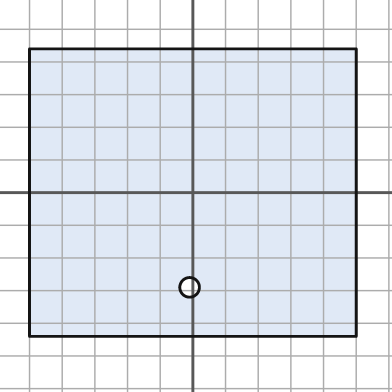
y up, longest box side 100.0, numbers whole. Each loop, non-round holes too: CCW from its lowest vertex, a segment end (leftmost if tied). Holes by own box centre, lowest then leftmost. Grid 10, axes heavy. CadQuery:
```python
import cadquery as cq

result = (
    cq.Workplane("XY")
    .moveTo(-50.0, -44.0)
    .lineTo(50.0, -44.0)
    .lineTo(50.0, 44.0)
    .lineTo(-50.0, 44.0)
    .close()
    .moveTo(-1.0, -29.0)
    .circle(3.0)
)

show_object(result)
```